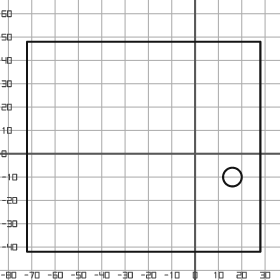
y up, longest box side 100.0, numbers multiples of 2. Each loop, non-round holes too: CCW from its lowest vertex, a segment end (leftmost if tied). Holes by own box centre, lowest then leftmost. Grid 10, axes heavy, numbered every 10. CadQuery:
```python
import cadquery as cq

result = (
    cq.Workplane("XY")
    .moveTo(-72.0, -42.0)
    .lineTo(28.0, -42.0)
    .lineTo(28.0, 48.0)
    .lineTo(-72.0, 48.0)
    .close()
    .moveTo(16.0, -10.0)
    .circle(4.0)
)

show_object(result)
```